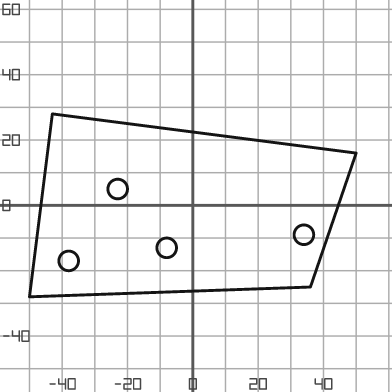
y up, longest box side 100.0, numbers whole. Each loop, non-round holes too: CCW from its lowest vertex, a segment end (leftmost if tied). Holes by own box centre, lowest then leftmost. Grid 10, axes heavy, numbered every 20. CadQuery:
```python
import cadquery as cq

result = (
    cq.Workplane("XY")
    .moveTo(-50.0, -28.0)
    .lineTo(36.0, -25.0)
    .lineTo(50.0, 16.0)
    .lineTo(-43.0, 28.0)
    .close()
    .moveTo(-38.0, -17.0)
    .circle(3.0)
    .moveTo(-8.0, -13.0)
    .circle(3.0)
    .moveTo(34.0, -9.0)
    .circle(3.0)
    .moveTo(-23.0, 5.0)
    .circle(3.0)
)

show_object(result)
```